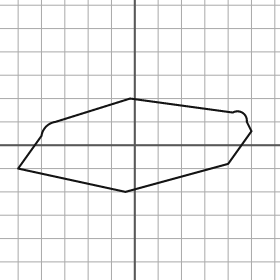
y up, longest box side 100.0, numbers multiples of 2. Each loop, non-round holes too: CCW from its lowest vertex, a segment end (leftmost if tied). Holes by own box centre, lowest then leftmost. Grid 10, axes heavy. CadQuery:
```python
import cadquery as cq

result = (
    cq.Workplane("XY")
    .moveTo(-4.0, -20.0)
    .lineTo(40.0, -8.0)
    .lineTo(50.0, 6.0)
    .lineTo(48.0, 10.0)
    .threePointArc((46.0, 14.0), (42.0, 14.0))
    .lineTo(-2.0, 20.0)
    .lineTo(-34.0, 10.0)
    .threePointArc((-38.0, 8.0), (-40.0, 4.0))
    .lineTo(-50.0, -10.0)
    .close()
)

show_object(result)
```